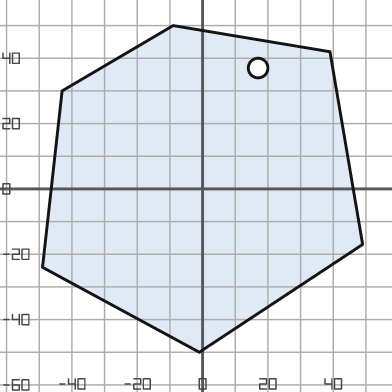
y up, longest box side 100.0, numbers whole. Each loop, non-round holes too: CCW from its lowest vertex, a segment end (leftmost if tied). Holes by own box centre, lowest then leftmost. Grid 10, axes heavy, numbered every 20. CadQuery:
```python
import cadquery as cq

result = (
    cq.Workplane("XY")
    .moveTo(-1.0, -50.0)
    .lineTo(49.0, -17.0)
    .lineTo(39.0, 42.0)
    .lineTo(-9.0, 50.0)
    .lineTo(-43.0, 30.0)
    .lineTo(-49.0, -24.0)
    .close()
    .moveTo(17.0, 37.0)
    .circle(3.0)
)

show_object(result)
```